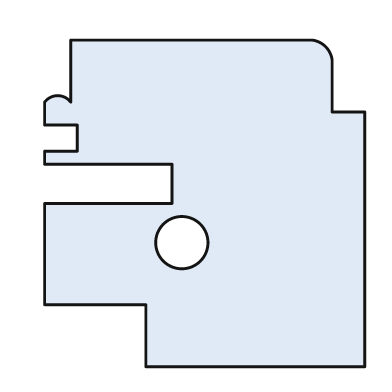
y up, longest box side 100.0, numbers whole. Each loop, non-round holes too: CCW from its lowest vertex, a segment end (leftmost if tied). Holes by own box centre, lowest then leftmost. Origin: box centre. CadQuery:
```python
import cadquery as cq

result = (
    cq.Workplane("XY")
    .moveTo(-18.0, -50.0)
    .lineTo(49.0, -50.0)
    .lineTo(49.0, 28.0)
    .lineTo(39.0, 28.0)
    .lineTo(39.0, 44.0)
    .threePointArc((37.0, 48.0), (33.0, 50.0))
    .lineTo(-41.0, 50.0)
    .lineTo(-41.0, 31.0)
    .threePointArc((-45.0, 33.0), (-49.0, 31.0))
    .lineTo(-49.0, 24.0)
    .lineTo(-39.0, 24.0)
    .lineTo(-39.0, 16.0)
    .lineTo(-49.0, 16.0)
    .lineTo(-49.0, 12.0)
    .lineTo(-10.0, 12.0)
    .lineTo(-10.0, 0.0)
    .lineTo(-49.0, 0.0)
    .lineTo(-49.0, -31.0)
    .lineTo(-18.0, -31.0)
    .close()
    .moveTo(-7.0, -12.0)
    .circle(8.0)
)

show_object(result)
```